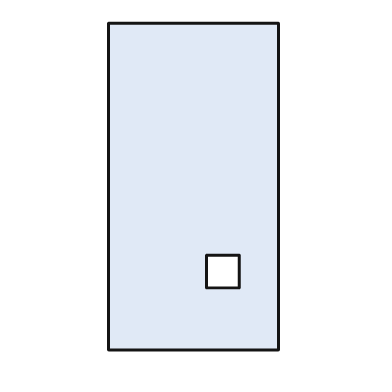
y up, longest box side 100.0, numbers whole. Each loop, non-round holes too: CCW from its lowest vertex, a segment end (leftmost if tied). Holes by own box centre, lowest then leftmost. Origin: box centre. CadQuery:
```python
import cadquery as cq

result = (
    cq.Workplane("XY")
    .moveTo(-26.0, -50.0)
    .lineTo(26.0, -50.0)
    .lineTo(26.0, 50.0)
    .lineTo(-26.0, 50.0)
    .close()
    .moveTo(4.0, -31.0)
    .lineTo(14.0, -31.0)
    .lineTo(14.0, -21.0)
    .lineTo(4.0, -21.0)
    .close()
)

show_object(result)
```